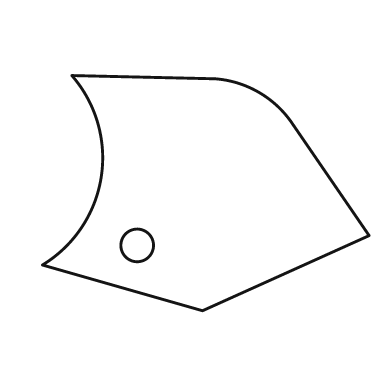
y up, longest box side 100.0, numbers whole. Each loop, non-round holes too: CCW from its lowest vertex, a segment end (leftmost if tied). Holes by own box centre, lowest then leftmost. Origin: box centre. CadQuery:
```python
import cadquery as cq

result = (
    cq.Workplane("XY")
    .moveTo(-1.0, -36.0)
    .lineTo(50.0, -13.0)
    .lineTo(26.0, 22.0)
    .threePointArc((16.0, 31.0), (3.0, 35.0))
    .lineTo(-41.0, 36.0)
    .threePointArc((-32.0, 5.0), (-50.0, -22.0))
    .close()
    .moveTo(-21.0, -16.0)
    .circle(5.0)
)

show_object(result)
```